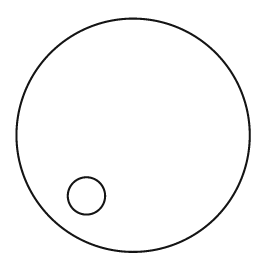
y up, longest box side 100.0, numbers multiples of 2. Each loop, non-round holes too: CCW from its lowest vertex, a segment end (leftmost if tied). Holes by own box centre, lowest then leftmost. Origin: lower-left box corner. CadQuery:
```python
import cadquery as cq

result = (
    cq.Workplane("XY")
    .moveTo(50.0, 50.0)
    .circle(50.0)
    .moveTo(30.0, 24.0)
    .circle(8.0)
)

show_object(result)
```